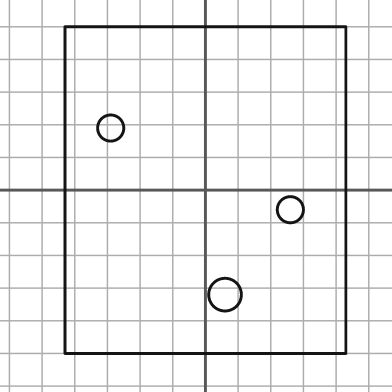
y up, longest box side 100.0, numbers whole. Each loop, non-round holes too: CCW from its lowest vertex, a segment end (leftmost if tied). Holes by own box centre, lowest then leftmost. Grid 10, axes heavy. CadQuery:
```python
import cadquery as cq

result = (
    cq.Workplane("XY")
    .moveTo(-43.0, -50.0)
    .lineTo(43.0, -50.0)
    .lineTo(43.0, 50.0)
    .lineTo(-43.0, 50.0)
    .close()
    .moveTo(6.0, -32.0)
    .circle(5.0)
    .moveTo(26.0, -6.0)
    .circle(4.0)
    .moveTo(-29.0, 19.0)
    .circle(4.0)
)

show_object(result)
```